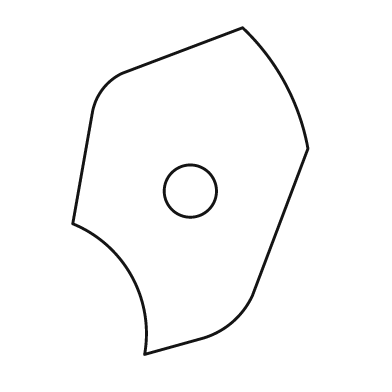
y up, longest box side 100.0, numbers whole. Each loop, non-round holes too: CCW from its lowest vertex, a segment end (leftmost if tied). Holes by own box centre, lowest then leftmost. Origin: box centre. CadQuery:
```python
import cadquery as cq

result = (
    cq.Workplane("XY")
    .moveTo(-14.0, -50.0)
    .lineTo(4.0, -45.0)
    .threePointArc((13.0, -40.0), (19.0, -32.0))
    .lineTo(36.0, 13.0)
    .threePointArc((29.0, 33.0), (16.0, 50.0))
    .lineTo(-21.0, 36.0)
    .threePointArc((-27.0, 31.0), (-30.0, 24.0))
    .lineTo(-36.0, -10.0)
    .threePointArc((-18.0, -26.0), (-14.0, -50.0))
    .close()
    .moveTo(0.0, 0.0)
    .circle(8.0)
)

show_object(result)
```